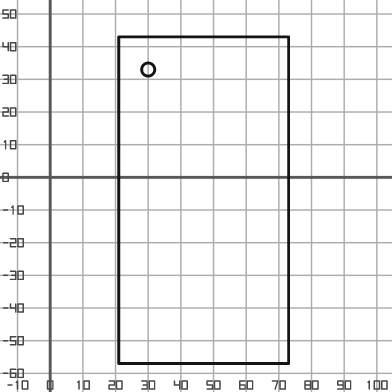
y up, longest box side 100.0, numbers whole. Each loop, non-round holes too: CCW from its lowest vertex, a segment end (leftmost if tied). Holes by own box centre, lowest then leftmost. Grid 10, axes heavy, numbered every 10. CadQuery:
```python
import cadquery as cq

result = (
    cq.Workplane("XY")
    .moveTo(21.0, -57.0)
    .lineTo(73.0, -57.0)
    .lineTo(73.0, 43.0)
    .lineTo(21.0, 43.0)
    .close()
    .moveTo(30.0, 33.0)
    .circle(2.0)
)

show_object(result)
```